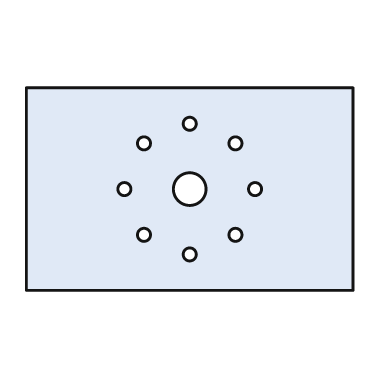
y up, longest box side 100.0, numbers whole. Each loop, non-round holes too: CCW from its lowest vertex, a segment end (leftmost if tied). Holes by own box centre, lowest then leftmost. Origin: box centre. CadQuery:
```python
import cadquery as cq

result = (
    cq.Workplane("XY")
    .moveTo(-50.0, -31.0)
    .lineTo(50.0, -31.0)
    .lineTo(50.0, 31.0)
    .lineTo(-50.0, 31.0)
    .close()
    .moveTo(0.0, -20.0)
    .circle(2.0)
    .moveTo(-14.0, -14.0)
    .circle(2.0)
    .moveTo(14.0, -14.0)
    .circle(2.0)
    .moveTo(-20.0, 0.0)
    .circle(2.0)
    .moveTo(0.0, 0.0)
    .circle(5.0)
    .moveTo(20.0, 0.0)
    .circle(2.0)
    .moveTo(-14.0, 14.0)
    .circle(2.0)
    .moveTo(14.0, 14.0)
    .circle(2.0)
    .moveTo(0.0, 20.0)
    .circle(2.0)
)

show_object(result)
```